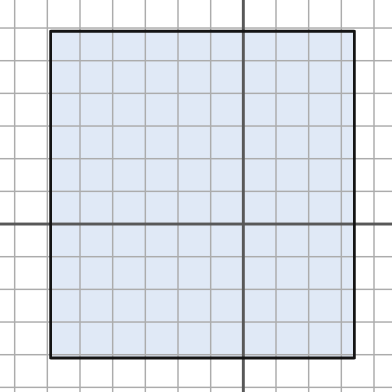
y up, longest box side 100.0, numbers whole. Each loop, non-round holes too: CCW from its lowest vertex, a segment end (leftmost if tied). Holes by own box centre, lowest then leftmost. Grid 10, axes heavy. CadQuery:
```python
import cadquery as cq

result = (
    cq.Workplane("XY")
    .moveTo(-59.0, -41.0)
    .lineTo(34.0, -41.0)
    .lineTo(34.0, 59.0)
    .lineTo(-59.0, 59.0)
    .close()
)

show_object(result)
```